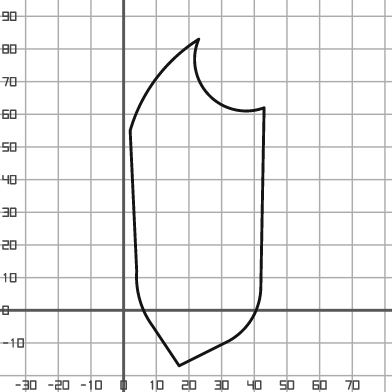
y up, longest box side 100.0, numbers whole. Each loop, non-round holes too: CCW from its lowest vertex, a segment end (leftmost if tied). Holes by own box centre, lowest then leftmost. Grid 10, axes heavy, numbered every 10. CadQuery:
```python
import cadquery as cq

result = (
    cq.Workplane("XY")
    .moveTo(17.0, -17.0)
    .lineTo(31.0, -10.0)
    .threePointArc((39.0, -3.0), (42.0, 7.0))
    .lineTo(43.0, 62.0)
    .threePointArc((26.0, 66.0), (23.0, 83.0))
    .threePointArc((10.0, 71.0), (2.0, 55.0))
    .lineTo(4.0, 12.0)
    .threePointArc((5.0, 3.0), (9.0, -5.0))
    .close()
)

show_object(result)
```